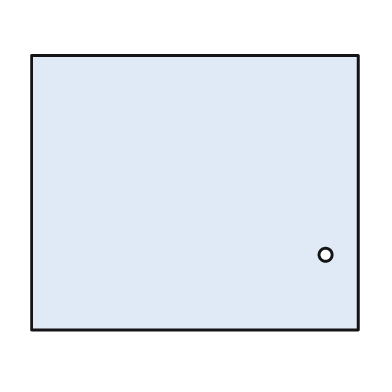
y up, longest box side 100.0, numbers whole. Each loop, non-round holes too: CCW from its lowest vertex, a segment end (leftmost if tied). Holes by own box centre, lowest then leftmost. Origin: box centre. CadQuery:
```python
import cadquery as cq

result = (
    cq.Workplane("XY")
    .moveTo(-50.0, -42.0)
    .lineTo(50.0, -42.0)
    .lineTo(50.0, 42.0)
    .lineTo(-50.0, 42.0)
    .close()
    .moveTo(40.0, -19.0)
    .circle(2.0)
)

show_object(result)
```